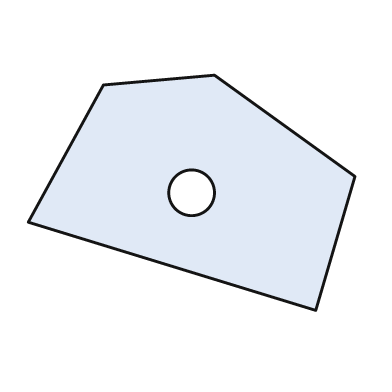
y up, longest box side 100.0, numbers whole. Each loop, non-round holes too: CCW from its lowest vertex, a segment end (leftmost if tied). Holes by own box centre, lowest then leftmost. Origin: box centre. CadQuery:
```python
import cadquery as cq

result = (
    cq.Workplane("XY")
    .moveTo(38.0, -36.0)
    .lineTo(50.0, 5.0)
    .lineTo(7.0, 36.0)
    .lineTo(-27.0, 33.0)
    .lineTo(-50.0, -9.0)
    .close()
    .moveTo(0.0, 0.0)
    .circle(7.0)
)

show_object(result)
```